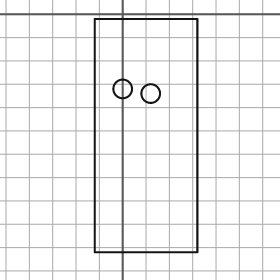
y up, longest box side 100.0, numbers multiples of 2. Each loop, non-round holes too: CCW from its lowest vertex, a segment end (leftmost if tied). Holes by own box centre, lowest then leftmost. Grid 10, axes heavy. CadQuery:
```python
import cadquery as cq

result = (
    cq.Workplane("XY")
    .moveTo(-12.0, -102.0)
    .lineTo(32.0, -102.0)
    .lineTo(32.0, -2.0)
    .lineTo(-12.0, -2.0)
    .close()
    .moveTo(12.0, -34.0)
    .circle(4.0)
    .moveTo(0.0, -32.0)
    .circle(4.0)
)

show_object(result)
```